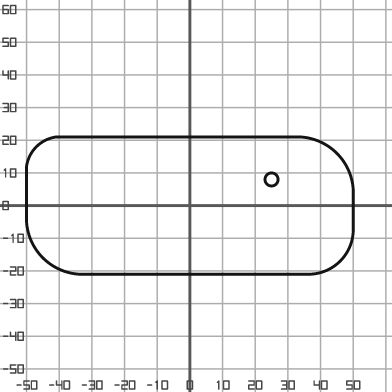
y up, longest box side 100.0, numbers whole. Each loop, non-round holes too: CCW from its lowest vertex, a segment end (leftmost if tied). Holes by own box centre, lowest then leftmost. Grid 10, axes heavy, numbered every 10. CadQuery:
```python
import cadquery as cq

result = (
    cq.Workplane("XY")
    .moveTo(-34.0, -21.0)
    .lineTo(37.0, -21.0)
    .threePointArc((46.0, -17.0), (50.0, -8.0))
    .lineTo(50.0, 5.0)
    .threePointArc((45.0, 16.0), (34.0, 21.0))
    .lineTo(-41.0, 21.0)
    .threePointArc((-47.0, 18.0), (-50.0, 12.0))
    .lineTo(-50.0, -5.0)
    .threePointArc((-45.0, -16.0), (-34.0, -21.0))
    .close()
    .moveTo(25.0, 8.0)
    .circle(2.0)
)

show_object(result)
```